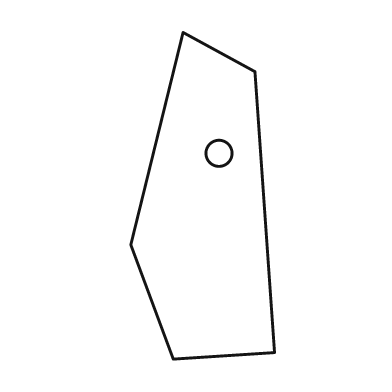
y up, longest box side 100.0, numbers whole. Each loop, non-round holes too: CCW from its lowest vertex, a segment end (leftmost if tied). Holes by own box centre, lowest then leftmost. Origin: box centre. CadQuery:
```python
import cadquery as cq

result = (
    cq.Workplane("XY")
    .moveTo(-9.0, -50.0)
    .lineTo(22.0, -48.0)
    .lineTo(16.0, 38.0)
    .lineTo(-6.0, 50.0)
    .lineTo(-22.0, -15.0)
    .close()
    .moveTo(5.0, 13.0)
    .circle(4.0)
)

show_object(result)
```